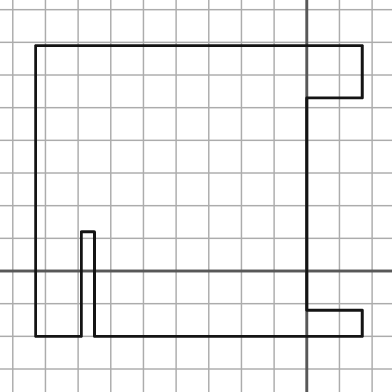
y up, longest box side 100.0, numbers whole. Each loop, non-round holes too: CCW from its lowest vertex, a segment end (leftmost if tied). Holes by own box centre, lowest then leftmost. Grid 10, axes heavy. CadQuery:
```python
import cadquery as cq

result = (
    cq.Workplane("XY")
    .moveTo(-83.0, -20.0)
    .lineTo(-69.0, -20.0)
    .lineTo(-69.0, 12.0)
    .lineTo(-65.0, 12.0)
    .lineTo(-65.0, -20.0)
    .lineTo(17.0, -20.0)
    .lineTo(17.0, -12.0)
    .lineTo(0.0, -12.0)
    .lineTo(0.0, 53.0)
    .lineTo(17.0, 53.0)
    .lineTo(17.0, 69.0)
    .lineTo(-83.0, 69.0)
    .close()
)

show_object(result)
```